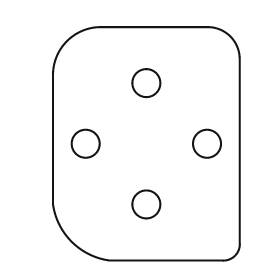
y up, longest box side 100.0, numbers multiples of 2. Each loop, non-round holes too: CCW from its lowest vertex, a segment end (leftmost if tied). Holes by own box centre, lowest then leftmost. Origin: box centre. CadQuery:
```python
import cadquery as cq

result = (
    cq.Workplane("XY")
    .moveTo(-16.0, -50.0)
    .lineTo(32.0, -50.0)
    .threePointArc((38.0, -48.0), (40.0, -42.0))
    .lineTo(40.0, 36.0)
    .threePointArc((36.0, 46.0), (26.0, 50.0))
    .lineTo(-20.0, 50.0)
    .threePointArc((-34.0, 44.0), (-40.0, 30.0))
    .lineTo(-40.0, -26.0)
    .threePointArc((-32.0, -42.0), (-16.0, -50.0))
    .close()
    .moveTo(0.0, -26.0)
    .circle(6.0)
    .moveTo(-26.0, 0.0)
    .circle(6.0)
    .moveTo(26.0, 0.0)
    .circle(6.0)
    .moveTo(0.0, 26.0)
    .circle(6.0)
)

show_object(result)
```